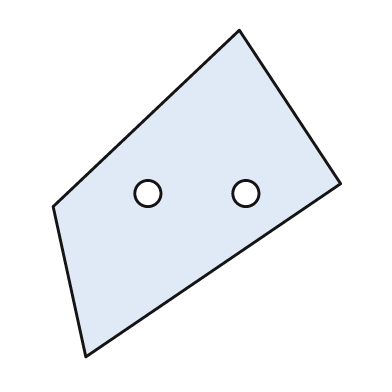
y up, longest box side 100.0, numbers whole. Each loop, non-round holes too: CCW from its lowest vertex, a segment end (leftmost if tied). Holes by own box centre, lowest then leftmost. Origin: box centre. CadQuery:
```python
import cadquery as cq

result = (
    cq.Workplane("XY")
    .moveTo(-34.0, -50.0)
    .lineTo(44.0, 3.0)
    .lineTo(13.0, 50.0)
    .lineTo(-44.0, -4.0)
    .close()
    .moveTo(-15.0, 0.0)
    .circle(4.0)
    .moveTo(15.0, 0.0)
    .circle(4.0)
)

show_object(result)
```